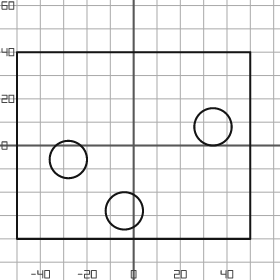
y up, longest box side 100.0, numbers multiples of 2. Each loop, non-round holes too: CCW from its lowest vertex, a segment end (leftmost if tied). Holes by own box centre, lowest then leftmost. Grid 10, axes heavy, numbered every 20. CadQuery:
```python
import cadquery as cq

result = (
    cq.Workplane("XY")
    .moveTo(-50.0, -40.0)
    .lineTo(50.0, -40.0)
    .lineTo(50.0, 40.0)
    .lineTo(-50.0, 40.0)
    .close()
    .moveTo(-4.0, -28.0)
    .circle(8.0)
    .moveTo(-28.0, -6.0)
    .circle(8.0)
    .moveTo(34.0, 8.0)
    .circle(8.0)
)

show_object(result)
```